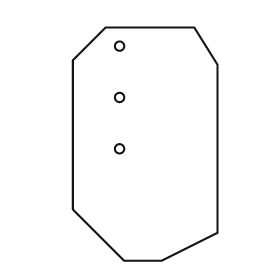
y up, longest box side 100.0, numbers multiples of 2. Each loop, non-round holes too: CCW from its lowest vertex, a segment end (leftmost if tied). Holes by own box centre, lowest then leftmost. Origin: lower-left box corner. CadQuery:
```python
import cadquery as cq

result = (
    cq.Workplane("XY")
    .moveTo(22.0, 0.0)
    .lineTo(38.0, 0.0)
    .lineTo(62.0, 12.0)
    .lineTo(62.0, 84.0)
    .lineTo(52.0, 100.0)
    .lineTo(14.0, 100.0)
    .lineTo(0.0, 86.0)
    .lineTo(0.0, 22.0)
    .close()
    .moveTo(20.0, 48.0)
    .circle(2.0)
    .moveTo(20.0, 70.0)
    .circle(2.0)
    .moveTo(20.0, 92.0)
    .circle(2.0)
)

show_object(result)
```